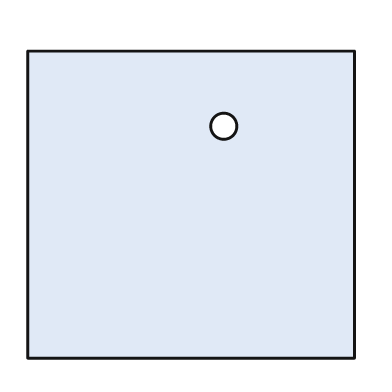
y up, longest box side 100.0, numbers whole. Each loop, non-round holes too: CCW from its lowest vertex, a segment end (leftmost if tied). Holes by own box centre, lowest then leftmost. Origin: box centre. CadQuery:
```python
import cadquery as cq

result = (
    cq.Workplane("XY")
    .moveTo(-50.0, -47.0)
    .lineTo(50.0, -47.0)
    .lineTo(50.0, 47.0)
    .lineTo(-50.0, 47.0)
    .close()
    .moveTo(10.0, 24.0)
    .circle(4.0)
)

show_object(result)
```